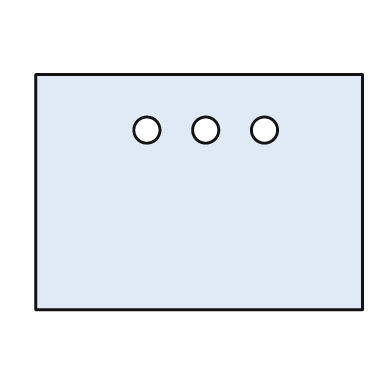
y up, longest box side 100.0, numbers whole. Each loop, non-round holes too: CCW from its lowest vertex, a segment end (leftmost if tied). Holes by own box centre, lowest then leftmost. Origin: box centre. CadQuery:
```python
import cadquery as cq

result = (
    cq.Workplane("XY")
    .moveTo(-50.0, -36.0)
    .lineTo(50.0, -36.0)
    .lineTo(50.0, 36.0)
    .lineTo(-50.0, 36.0)
    .close()
    .moveTo(-16.0, 19.0)
    .circle(4.0)
    .moveTo(2.0, 19.0)
    .circle(4.0)
    .moveTo(20.0, 19.0)
    .circle(4.0)
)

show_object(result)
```